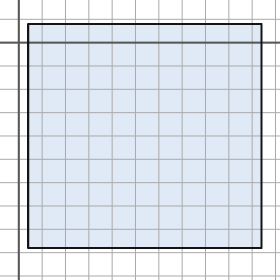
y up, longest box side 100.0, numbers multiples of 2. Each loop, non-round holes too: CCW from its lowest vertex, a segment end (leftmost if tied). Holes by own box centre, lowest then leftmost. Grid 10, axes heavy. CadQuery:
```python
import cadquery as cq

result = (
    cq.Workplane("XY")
    .moveTo(4.0, -88.0)
    .lineTo(104.0, -88.0)
    .lineTo(104.0, 8.0)
    .lineTo(4.0, 8.0)
    .close()
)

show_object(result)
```